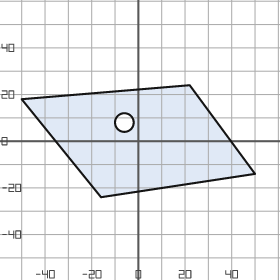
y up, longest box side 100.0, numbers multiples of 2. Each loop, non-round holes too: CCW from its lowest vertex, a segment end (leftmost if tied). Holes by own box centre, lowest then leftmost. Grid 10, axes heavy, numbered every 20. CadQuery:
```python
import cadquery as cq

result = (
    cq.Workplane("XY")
    .moveTo(-16.0, -24.0)
    .lineTo(50.0, -14.0)
    .lineTo(22.0, 24.0)
    .lineTo(-50.0, 18.0)
    .close()
    .moveTo(-6.0, 8.0)
    .circle(4.0)
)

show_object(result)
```